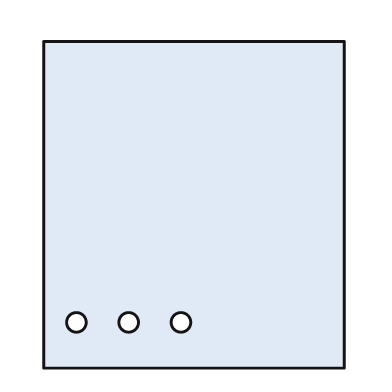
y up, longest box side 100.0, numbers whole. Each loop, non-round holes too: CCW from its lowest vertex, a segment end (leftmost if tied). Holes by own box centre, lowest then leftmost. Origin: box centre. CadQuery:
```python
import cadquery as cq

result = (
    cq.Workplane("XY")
    .moveTo(-46.0, -50.0)
    .lineTo(46.0, -50.0)
    .lineTo(46.0, 50.0)
    .lineTo(-46.0, 50.0)
    .close()
    .moveTo(-36.0, -36.0)
    .circle(3.0)
    .moveTo(-20.0, -36.0)
    .circle(3.0)
    .moveTo(-4.0, -36.0)
    .circle(3.0)
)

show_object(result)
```